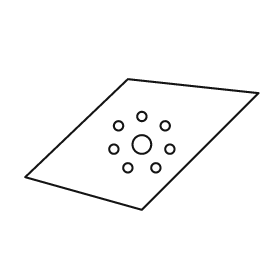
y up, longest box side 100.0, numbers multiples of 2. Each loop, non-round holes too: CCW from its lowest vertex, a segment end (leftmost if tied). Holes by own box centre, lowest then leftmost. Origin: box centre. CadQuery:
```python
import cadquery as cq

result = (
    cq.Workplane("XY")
    .moveTo(0.0, -28.0)
    .lineTo(50.0, 22.0)
    .lineTo(-6.0, 28.0)
    .lineTo(-50.0, -14.0)
    .close()
    .moveTo(-6.0, -10.0)
    .circle(2.0)
    .moveTo(6.0, -10.0)
    .circle(2.0)
    .moveTo(-12.0, -2.0)
    .circle(2.0)
    .moveTo(12.0, -2.0)
    .circle(2.0)
    .moveTo(0.0, 0.0)
    .circle(4.0)
    .moveTo(-10.0, 8.0)
    .circle(2.0)
    .moveTo(10.0, 8.0)
    .circle(2.0)
    .moveTo(0.0, 12.0)
    .circle(2.0)
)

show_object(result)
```